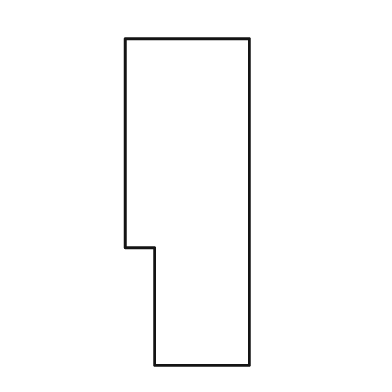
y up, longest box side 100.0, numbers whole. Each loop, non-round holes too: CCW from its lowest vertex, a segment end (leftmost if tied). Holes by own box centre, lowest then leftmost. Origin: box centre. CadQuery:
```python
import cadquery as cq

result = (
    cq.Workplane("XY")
    .moveTo(-10.0, -50.0)
    .lineTo(19.0, -50.0)
    .lineTo(19.0, 50.0)
    .lineTo(-19.0, 50.0)
    .lineTo(-19.0, -14.0)
    .lineTo(-10.0, -14.0)
    .close()
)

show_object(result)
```